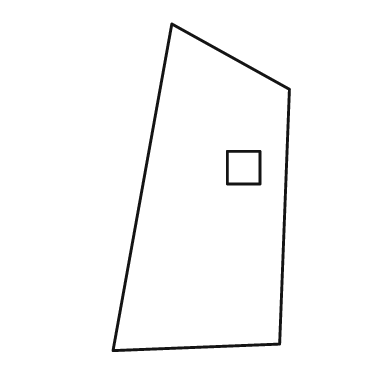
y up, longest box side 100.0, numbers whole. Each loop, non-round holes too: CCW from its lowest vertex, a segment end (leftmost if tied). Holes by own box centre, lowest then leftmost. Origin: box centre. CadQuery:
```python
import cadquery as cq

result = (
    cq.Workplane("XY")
    .moveTo(-27.0, -50.0)
    .lineTo(24.0, -48.0)
    .lineTo(27.0, 30.0)
    .lineTo(-9.0, 50.0)
    .close()
    .moveTo(8.0, 1.0)
    .lineTo(18.0, 1.0)
    .lineTo(18.0, 11.0)
    .lineTo(8.0, 11.0)
    .close()
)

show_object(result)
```